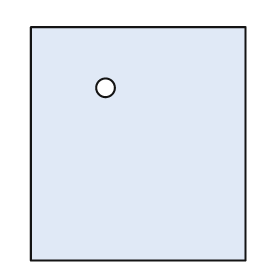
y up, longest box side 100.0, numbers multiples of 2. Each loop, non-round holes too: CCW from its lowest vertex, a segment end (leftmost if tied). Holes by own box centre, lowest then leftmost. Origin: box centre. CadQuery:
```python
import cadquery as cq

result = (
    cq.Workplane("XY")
    .moveTo(-46.0, -50.0)
    .lineTo(46.0, -50.0)
    .lineTo(46.0, 50.0)
    .lineTo(-46.0, 50.0)
    .close()
    .moveTo(-14.0, 24.0)
    .circle(4.0)
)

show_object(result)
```